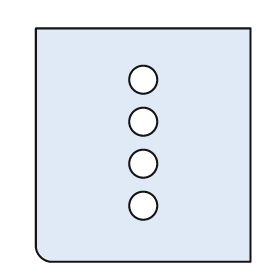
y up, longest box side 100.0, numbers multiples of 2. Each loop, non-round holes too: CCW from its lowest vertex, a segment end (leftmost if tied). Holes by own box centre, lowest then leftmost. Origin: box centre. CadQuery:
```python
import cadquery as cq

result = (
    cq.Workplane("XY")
    .moveTo(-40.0, -50.0)
    .lineTo(46.0, -50.0)
    .lineTo(46.0, 50.0)
    .lineTo(-46.0, 50.0)
    .lineTo(-46.0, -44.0)
    .threePointArc((-44.0, -48.0), (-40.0, -50.0))
    .close()
    .moveTo(0.0, -26.0)
    .circle(6.0)
    .moveTo(0.0, -8.0)
    .circle(6.0)
    .moveTo(0.0, 10.0)
    .circle(6.0)
    .moveTo(0.0, 28.0)
    .circle(6.0)
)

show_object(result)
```